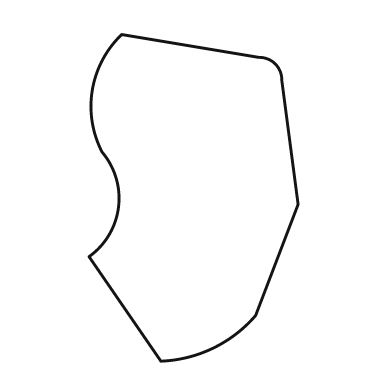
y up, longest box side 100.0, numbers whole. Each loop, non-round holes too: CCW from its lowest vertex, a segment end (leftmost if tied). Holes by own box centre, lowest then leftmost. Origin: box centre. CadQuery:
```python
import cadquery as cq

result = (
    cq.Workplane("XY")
    .moveTo(-10.0, -50.0)
    .threePointArc((6.0, -46.0), (19.0, -36.0))
    .lineTo(32.0, -2.0)
    .lineTo(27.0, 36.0)
    .threePointArc((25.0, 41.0), (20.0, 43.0))
    .lineTo(-22.0, 50.0)
    .threePointArc((-31.0, 33.0), (-28.0, 14.0))
    .threePointArc((-23.0, -3.0), (-32.0, -18.0))
    .close()
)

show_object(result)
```